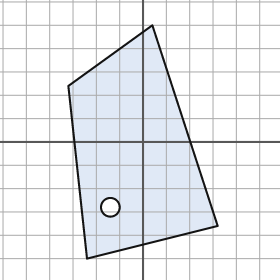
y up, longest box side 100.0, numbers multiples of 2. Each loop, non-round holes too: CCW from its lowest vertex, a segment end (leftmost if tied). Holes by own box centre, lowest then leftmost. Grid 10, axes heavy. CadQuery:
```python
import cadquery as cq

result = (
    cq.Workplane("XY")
    .moveTo(-24.0, -50.0)
    .lineTo(32.0, -36.0)
    .lineTo(4.0, 50.0)
    .lineTo(-32.0, 24.0)
    .close()
    .moveTo(-14.0, -28.0)
    .circle(4.0)
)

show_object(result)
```